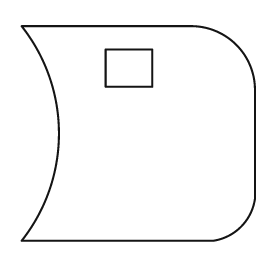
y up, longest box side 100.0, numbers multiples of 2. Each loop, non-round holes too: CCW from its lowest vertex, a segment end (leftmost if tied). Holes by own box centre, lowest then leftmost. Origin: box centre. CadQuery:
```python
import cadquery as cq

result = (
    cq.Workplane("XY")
    .moveTo(-50.0, -46.0)
    .lineTo(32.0, -46.0)
    .threePointArc((44.0, -40.0), (50.0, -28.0))
    .lineTo(50.0, 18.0)
    .threePointArc((42.0, 38.0), (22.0, 46.0))
    .lineTo(-50.0, 46.0)
    .threePointArc((-34.0, 0.0), (-50.0, -46.0))
    .close()
    .moveTo(-14.0, 20.0)
    .lineTo(6.0, 20.0)
    .lineTo(6.0, 36.0)
    .lineTo(-14.0, 36.0)
    .close()
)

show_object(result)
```